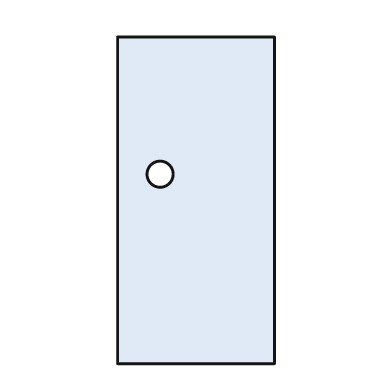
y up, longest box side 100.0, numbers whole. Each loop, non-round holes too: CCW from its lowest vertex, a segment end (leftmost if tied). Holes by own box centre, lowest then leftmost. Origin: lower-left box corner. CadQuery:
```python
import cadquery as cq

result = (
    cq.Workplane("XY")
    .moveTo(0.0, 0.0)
    .lineTo(48.0, 0.0)
    .lineTo(48.0, 100.0)
    .lineTo(0.0, 100.0)
    .close()
    .moveTo(13.0, 58.0)
    .circle(4.0)
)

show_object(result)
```